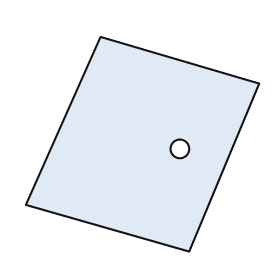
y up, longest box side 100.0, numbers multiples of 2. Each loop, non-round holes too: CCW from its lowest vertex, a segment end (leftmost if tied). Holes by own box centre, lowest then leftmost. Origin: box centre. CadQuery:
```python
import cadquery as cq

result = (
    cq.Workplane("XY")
    .moveTo(20.0, -46.0)
    .lineTo(50.0, 26.0)
    .lineTo(-18.0, 46.0)
    .lineTo(-50.0, -26.0)
    .close()
    .moveTo(16.0, -2.0)
    .circle(4.0)
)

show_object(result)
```